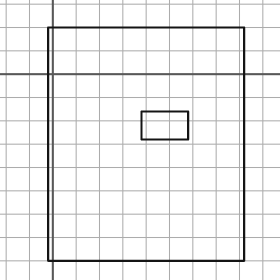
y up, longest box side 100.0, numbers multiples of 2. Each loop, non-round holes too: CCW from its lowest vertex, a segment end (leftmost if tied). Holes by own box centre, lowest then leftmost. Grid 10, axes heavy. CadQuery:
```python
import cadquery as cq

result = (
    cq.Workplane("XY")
    .moveTo(-2.0, -80.0)
    .lineTo(82.0, -80.0)
    .lineTo(82.0, 20.0)
    .lineTo(-2.0, 20.0)
    .close()
    .moveTo(38.0, -28.0)
    .lineTo(58.0, -28.0)
    .lineTo(58.0, -16.0)
    .lineTo(38.0, -16.0)
    .close()
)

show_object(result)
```